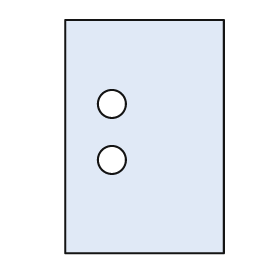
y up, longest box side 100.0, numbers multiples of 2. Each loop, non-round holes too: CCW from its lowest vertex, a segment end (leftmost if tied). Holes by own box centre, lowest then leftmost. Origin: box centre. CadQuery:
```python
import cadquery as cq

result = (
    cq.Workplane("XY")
    .moveTo(-34.0, -50.0)
    .lineTo(34.0, -50.0)
    .lineTo(34.0, 50.0)
    .lineTo(-34.0, 50.0)
    .close()
    .moveTo(-14.0, -10.0)
    .circle(6.0)
    .moveTo(-14.0, 14.0)
    .circle(6.0)
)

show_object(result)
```